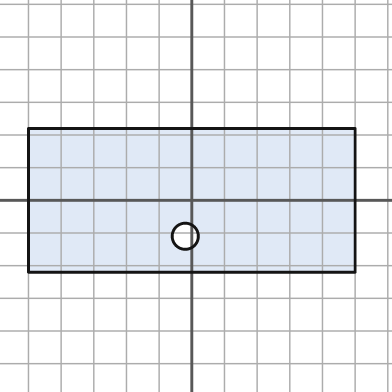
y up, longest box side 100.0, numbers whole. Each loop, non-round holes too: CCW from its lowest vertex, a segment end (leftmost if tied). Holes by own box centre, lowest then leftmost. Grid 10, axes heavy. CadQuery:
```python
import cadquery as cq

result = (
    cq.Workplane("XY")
    .moveTo(-50.0, -22.0)
    .lineTo(50.0, -22.0)
    .lineTo(50.0, 22.0)
    .lineTo(-50.0, 22.0)
    .close()
    .moveTo(-2.0, -11.0)
    .circle(4.0)
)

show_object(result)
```